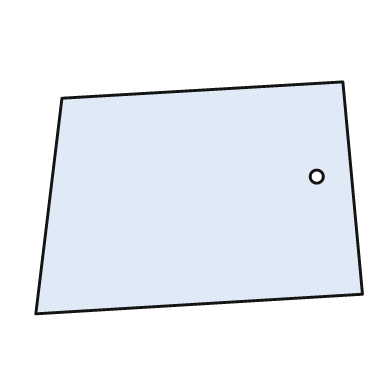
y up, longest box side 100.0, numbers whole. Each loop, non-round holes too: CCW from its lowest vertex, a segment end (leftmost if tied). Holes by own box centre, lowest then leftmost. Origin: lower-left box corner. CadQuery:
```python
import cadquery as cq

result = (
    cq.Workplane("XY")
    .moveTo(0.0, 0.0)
    .lineTo(100.0, 6.0)
    .lineTo(94.0, 71.0)
    .lineTo(8.0, 66.0)
    .close()
    .moveTo(86.0, 42.0)
    .circle(2.0)
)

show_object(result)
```